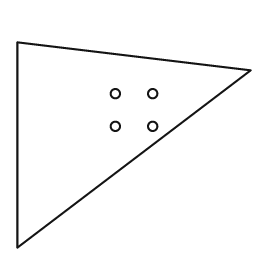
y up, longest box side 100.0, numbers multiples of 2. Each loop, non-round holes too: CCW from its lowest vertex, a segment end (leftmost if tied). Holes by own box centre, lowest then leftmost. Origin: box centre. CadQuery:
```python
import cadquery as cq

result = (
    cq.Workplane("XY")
    .moveTo(-50.0, -44.0)
    .lineTo(50.0, 32.0)
    .lineTo(-50.0, 44.0)
    .close()
    .moveTo(-8.0, 8.0)
    .circle(2.0)
    .moveTo(8.0, 8.0)
    .circle(2.0)
    .moveTo(-8.0, 22.0)
    .circle(2.0)
    .moveTo(8.0, 22.0)
    .circle(2.0)
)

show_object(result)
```